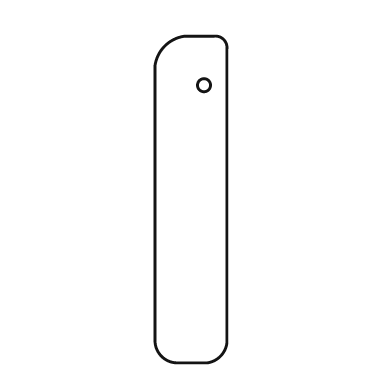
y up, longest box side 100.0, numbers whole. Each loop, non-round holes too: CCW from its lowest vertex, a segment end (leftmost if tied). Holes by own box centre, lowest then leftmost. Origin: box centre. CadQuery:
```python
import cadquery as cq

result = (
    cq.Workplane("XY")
    .moveTo(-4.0, -50.0)
    .lineTo(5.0, -50.0)
    .threePointArc((9.0, -48.0), (11.0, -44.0))
    .lineTo(11.0, 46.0)
    .threePointArc((10.0, 49.0), (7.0, 50.0))
    .lineTo(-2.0, 50.0)
    .threePointArc((-8.0, 47.0), (-11.0, 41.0))
    .lineTo(-11.0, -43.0)
    .threePointArc((-9.0, -48.0), (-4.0, -50.0))
    .close()
    .moveTo(4.0, 35.0)
    .circle(2.0)
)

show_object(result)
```